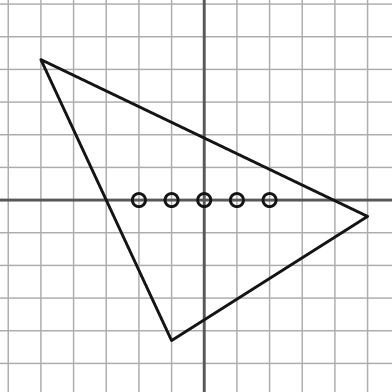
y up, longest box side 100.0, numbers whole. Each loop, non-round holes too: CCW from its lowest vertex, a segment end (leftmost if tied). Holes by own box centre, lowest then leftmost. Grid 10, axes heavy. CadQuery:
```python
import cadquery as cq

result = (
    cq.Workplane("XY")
    .moveTo(-10.0, -43.0)
    .lineTo(50.0, -5.0)
    .lineTo(-50.0, 43.0)
    .close()
    .moveTo(-20.0, 0.0)
    .circle(2.0)
    .moveTo(-10.0, 0.0)
    .circle(2.0)
    .moveTo(0.0, 0.0)
    .circle(2.0)
    .moveTo(10.0, 0.0)
    .circle(2.0)
    .moveTo(20.0, 0.0)
    .circle(2.0)
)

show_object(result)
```